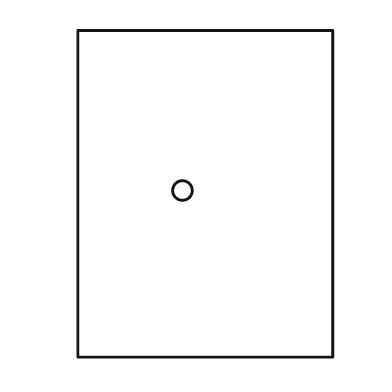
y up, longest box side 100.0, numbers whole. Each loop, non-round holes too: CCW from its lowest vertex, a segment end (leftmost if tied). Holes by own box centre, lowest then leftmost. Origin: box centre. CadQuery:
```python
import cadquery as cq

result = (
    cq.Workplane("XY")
    .moveTo(-39.0, -50.0)
    .lineTo(39.0, -50.0)
    .lineTo(39.0, 50.0)
    .lineTo(-39.0, 50.0)
    .close()
    .moveTo(-7.0, 1.0)
    .circle(3.0)
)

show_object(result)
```